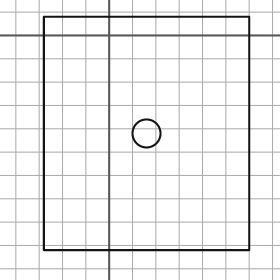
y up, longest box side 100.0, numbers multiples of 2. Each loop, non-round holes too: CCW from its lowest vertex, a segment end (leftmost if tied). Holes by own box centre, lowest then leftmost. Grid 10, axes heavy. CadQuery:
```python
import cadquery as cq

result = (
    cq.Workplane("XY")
    .moveTo(-28.0, -92.0)
    .lineTo(60.0, -92.0)
    .lineTo(60.0, 8.0)
    .lineTo(-28.0, 8.0)
    .close()
    .moveTo(16.0, -42.0)
    .circle(6.0)
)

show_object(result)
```